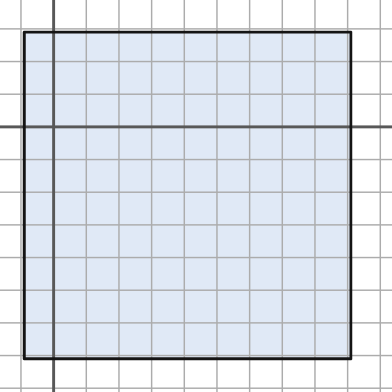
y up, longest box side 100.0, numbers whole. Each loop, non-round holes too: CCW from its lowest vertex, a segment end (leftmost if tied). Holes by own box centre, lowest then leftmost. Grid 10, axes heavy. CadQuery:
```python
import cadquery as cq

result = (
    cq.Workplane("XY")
    .moveTo(-9.0, -71.0)
    .lineTo(91.0, -71.0)
    .lineTo(91.0, 29.0)
    .lineTo(-9.0, 29.0)
    .close()
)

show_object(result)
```